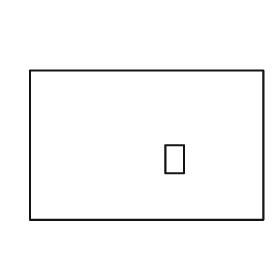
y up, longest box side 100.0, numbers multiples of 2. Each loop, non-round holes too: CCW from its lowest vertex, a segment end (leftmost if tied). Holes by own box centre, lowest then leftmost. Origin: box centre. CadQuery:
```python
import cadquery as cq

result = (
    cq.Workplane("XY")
    .moveTo(-50.0, -32.0)
    .lineTo(50.0, -32.0)
    .lineTo(50.0, 32.0)
    .lineTo(-50.0, 32.0)
    .close()
    .moveTo(8.0, -12.0)
    .lineTo(16.0, -12.0)
    .lineTo(16.0, 0.0)
    .lineTo(8.0, 0.0)
    .close()
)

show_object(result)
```